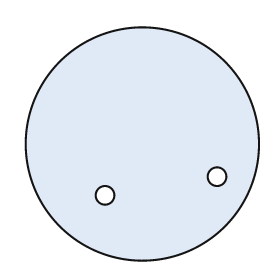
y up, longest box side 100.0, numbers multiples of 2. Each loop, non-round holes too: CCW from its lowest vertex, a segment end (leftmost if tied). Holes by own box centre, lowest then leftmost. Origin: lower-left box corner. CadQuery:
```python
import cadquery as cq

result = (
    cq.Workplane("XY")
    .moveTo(50.0, 50.0)
    .circle(50.0)
    .moveTo(34.0, 28.0)
    .circle(4.0)
    .moveTo(82.0, 36.0)
    .circle(4.0)
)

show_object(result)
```